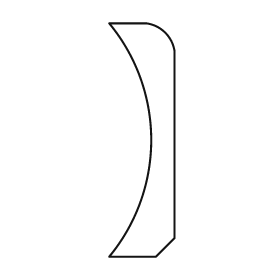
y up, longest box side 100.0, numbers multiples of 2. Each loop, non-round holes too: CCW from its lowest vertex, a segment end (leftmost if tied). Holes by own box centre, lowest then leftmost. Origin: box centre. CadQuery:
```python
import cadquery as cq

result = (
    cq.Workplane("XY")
    .moveTo(-14.0, -50.0)
    .lineTo(6.0, -50.0)
    .lineTo(14.0, -42.0)
    .lineTo(14.0, 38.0)
    .threePointArc((10.0, 46.0), (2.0, 50.0))
    .lineTo(-14.0, 50.0)
    .threePointArc((4.0, 0.0), (-14.0, -50.0))
    .close()
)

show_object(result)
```